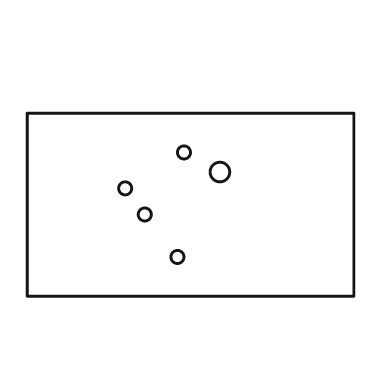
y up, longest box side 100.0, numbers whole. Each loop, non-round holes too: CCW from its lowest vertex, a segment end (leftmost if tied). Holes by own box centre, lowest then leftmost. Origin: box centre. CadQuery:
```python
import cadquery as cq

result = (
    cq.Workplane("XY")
    .moveTo(-50.0, -28.0)
    .lineTo(50.0, -28.0)
    .lineTo(50.0, 28.0)
    .lineTo(-50.0, 28.0)
    .close()
    .moveTo(-4.0, -16.0)
    .circle(2.0)
    .moveTo(-14.0, -3.0)
    .circle(2.0)
    .moveTo(-20.0, 5.0)
    .circle(2.0)
    .moveTo(9.0, 10.0)
    .circle(3.0)
    .moveTo(-2.0, 16.0)
    .circle(2.0)
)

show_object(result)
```